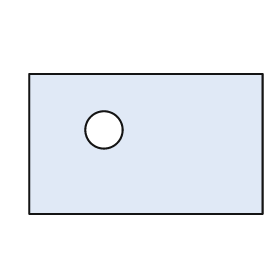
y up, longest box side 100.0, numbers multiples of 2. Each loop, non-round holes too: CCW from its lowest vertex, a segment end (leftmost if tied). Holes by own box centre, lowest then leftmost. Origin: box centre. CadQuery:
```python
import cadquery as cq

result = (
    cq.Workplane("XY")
    .moveTo(-50.0, -30.0)
    .lineTo(50.0, -30.0)
    .lineTo(50.0, 30.0)
    .lineTo(-50.0, 30.0)
    .close()
    .moveTo(-18.0, 6.0)
    .circle(8.0)
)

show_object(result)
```